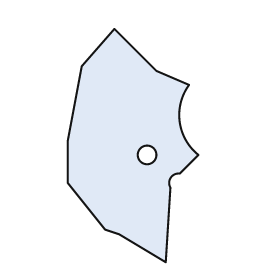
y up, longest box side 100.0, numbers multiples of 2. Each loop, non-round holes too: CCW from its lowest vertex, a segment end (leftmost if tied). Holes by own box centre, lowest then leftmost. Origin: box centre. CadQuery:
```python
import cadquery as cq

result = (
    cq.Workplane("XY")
    .moveTo(14.0, -50.0)
    .lineTo(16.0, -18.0)
    .threePointArc((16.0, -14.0), (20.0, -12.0))
    .lineTo(28.0, -4.0)
    .threePointArc((20.0, 10.0), (24.0, 26.0))
    .lineTo(10.0, 32.0)
    .lineTo(-8.0, 50.0)
    .lineTo(-22.0, 34.0)
    .lineTo(-28.0, 2.0)
    .lineTo(-28.0, -16.0)
    .lineTo(-12.0, -36.0)
    .lineTo(-6.0, -38.0)
    .close()
    .moveTo(6.0, -4.0)
    .circle(4.0)
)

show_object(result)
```